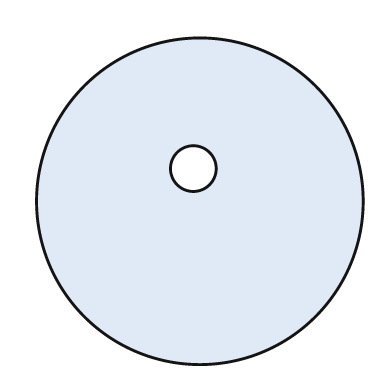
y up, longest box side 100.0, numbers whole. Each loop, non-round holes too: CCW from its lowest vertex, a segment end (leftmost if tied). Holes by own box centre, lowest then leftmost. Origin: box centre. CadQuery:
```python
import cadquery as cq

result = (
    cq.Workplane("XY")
    .moveTo(0.0, 0.0)
    .circle(50.0)
    .moveTo(-2.0, 10.0)
    .circle(7.0)
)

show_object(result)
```